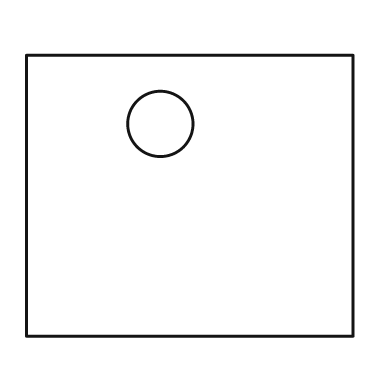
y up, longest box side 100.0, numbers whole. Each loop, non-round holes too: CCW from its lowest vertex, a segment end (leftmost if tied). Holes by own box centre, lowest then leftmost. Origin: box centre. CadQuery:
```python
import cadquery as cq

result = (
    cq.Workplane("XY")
    .moveTo(-50.0, -43.0)
    .lineTo(50.0, -43.0)
    .lineTo(50.0, 43.0)
    .lineTo(-50.0, 43.0)
    .close()
    .moveTo(-9.0, 22.0)
    .circle(10.0)
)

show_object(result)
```